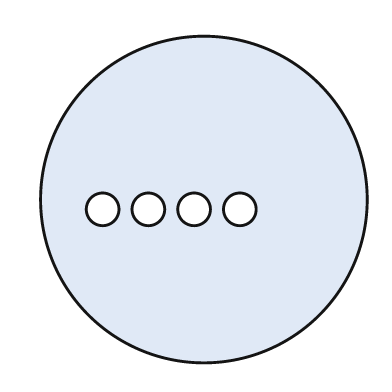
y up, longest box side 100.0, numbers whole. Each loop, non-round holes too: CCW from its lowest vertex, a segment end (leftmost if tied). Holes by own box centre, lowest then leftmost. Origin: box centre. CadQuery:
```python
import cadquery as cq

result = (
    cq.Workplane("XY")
    .moveTo(0.0, 0.0)
    .circle(50.0)
    .moveTo(-31.0, -3.0)
    .circle(5.0)
    .moveTo(-17.0, -3.0)
    .circle(5.0)
    .moveTo(-3.0, -3.0)
    .circle(5.0)
    .moveTo(11.0, -3.0)
    .circle(5.0)
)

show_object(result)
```